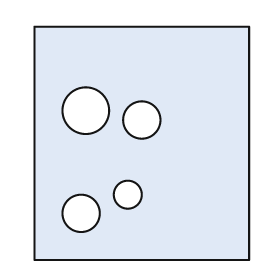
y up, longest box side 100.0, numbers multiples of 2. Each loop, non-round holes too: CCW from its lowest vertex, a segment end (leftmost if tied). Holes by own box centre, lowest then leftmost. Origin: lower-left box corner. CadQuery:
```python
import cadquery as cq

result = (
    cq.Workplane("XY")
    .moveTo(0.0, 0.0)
    .lineTo(92.0, 0.0)
    .lineTo(92.0, 100.0)
    .lineTo(0.0, 100.0)
    .close()
    .moveTo(20.0, 20.0)
    .circle(8.0)
    .moveTo(40.0, 28.0)
    .circle(6.0)
    .moveTo(46.0, 60.0)
    .circle(8.0)
    .moveTo(22.0, 64.0)
    .circle(10.0)
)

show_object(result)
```